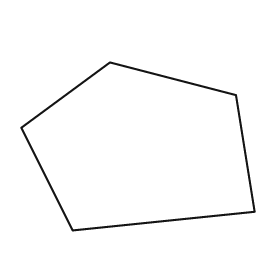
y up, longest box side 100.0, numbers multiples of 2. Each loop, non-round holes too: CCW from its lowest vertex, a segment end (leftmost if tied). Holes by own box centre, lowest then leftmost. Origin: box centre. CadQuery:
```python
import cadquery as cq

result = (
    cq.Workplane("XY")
    .moveTo(-28.0, -36.0)
    .lineTo(50.0, -28.0)
    .lineTo(42.0, 22.0)
    .lineTo(-12.0, 36.0)
    .lineTo(-50.0, 8.0)
    .close()
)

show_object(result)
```